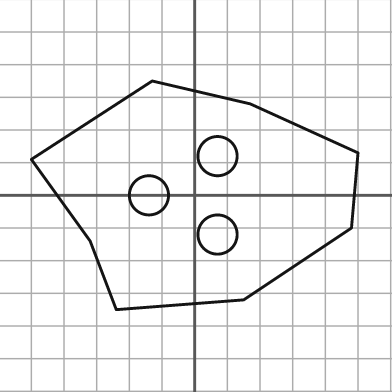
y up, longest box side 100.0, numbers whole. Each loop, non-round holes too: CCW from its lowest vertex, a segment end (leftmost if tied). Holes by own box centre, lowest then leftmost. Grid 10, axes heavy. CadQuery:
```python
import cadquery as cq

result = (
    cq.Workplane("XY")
    .moveTo(-24.0, -35.0)
    .lineTo(15.0, -32.0)
    .lineTo(48.0, -10.0)
    .lineTo(50.0, 13.0)
    .lineTo(17.0, 28.0)
    .lineTo(-13.0, 35.0)
    .lineTo(-50.0, 11.0)
    .lineTo(-32.0, -14.0)
    .close()
    .moveTo(7.0, -12.0)
    .circle(6.0)
    .moveTo(-14.0, 0.0)
    .circle(6.0)
    .moveTo(7.0, 12.0)
    .circle(6.0)
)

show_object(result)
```